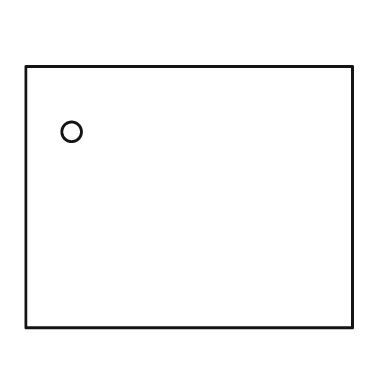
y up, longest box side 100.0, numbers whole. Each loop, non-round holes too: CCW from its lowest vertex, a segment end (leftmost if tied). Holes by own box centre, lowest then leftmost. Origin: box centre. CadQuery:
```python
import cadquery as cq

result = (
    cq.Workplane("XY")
    .moveTo(-50.0, -40.0)
    .lineTo(50.0, -40.0)
    .lineTo(50.0, 40.0)
    .lineTo(-50.0, 40.0)
    .close()
    .moveTo(-36.0, 20.0)
    .circle(3.0)
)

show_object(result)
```